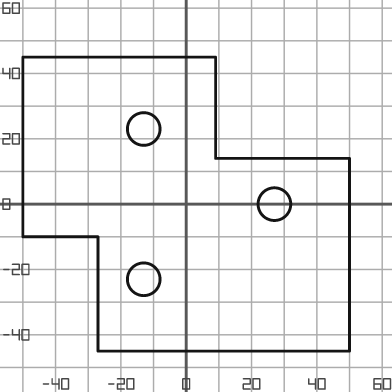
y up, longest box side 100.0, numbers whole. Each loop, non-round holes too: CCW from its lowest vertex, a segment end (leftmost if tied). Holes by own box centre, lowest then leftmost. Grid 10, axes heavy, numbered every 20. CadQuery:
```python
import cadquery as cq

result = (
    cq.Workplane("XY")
    .moveTo(-27.0, -45.0)
    .lineTo(50.0, -45.0)
    .lineTo(50.0, 14.0)
    .lineTo(9.0, 14.0)
    .lineTo(9.0, 45.0)
    .lineTo(-50.0, 45.0)
    .lineTo(-50.0, -10.0)
    .lineTo(-27.0, -10.0)
    .close()
    .moveTo(-13.0, -23.0)
    .circle(5.0)
    .moveTo(27.0, 0.0)
    .circle(5.0)
    .moveTo(-13.0, 23.0)
    .circle(5.0)
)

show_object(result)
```